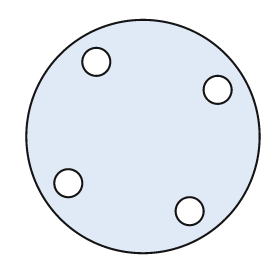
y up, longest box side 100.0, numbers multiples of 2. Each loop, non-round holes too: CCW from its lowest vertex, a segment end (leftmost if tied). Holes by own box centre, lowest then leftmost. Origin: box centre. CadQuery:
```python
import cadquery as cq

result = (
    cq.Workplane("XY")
    .moveTo(0.0, 0.0)
    .circle(50.0)
    .moveTo(20.0, -32.0)
    .circle(6.0)
    .moveTo(-32.0, -20.0)
    .circle(6.0)
    .moveTo(32.0, 20.0)
    .circle(6.0)
    .moveTo(-20.0, 32.0)
    .circle(6.0)
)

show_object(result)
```